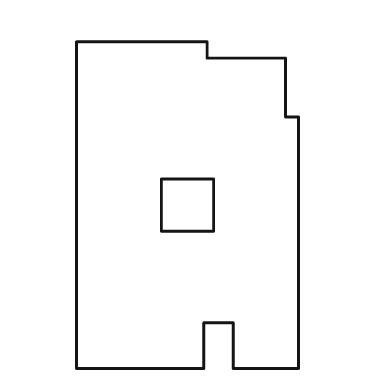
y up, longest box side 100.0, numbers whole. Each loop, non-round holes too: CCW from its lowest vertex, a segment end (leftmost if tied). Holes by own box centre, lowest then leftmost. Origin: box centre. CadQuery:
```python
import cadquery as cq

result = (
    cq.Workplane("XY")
    .moveTo(-34.0, -50.0)
    .lineTo(5.0, -50.0)
    .lineTo(5.0, -36.0)
    .lineTo(14.0, -36.0)
    .lineTo(14.0, -50.0)
    .lineTo(34.0, -50.0)
    .lineTo(34.0, 27.0)
    .lineTo(30.0, 27.0)
    .lineTo(30.0, 45.0)
    .lineTo(6.0, 45.0)
    .lineTo(6.0, 50.0)
    .lineTo(-34.0, 50.0)
    .close()
    .moveTo(-8.0, -8.0)
    .lineTo(8.0, -8.0)
    .lineTo(8.0, 8.0)
    .lineTo(-8.0, 8.0)
    .close()
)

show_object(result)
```